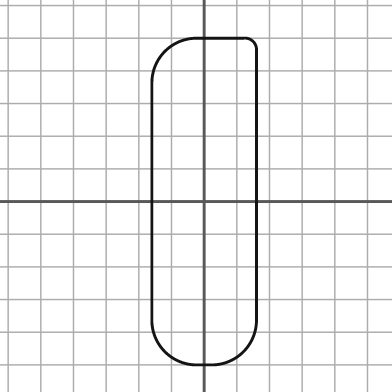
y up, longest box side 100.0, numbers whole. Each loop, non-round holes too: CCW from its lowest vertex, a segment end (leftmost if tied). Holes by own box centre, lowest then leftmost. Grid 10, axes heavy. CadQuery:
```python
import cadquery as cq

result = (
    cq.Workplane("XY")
    .moveTo(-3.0, -50.0)
    .lineTo(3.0, -50.0)
    .threePointArc((12.0, -46.0), (16.0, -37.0))
    .lineTo(16.0, 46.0)
    .threePointArc((15.0, 49.0), (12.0, 50.0))
    .lineTo(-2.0, 50.0)
    .threePointArc((-12.0, 46.0), (-16.0, 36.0))
    .lineTo(-16.0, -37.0)
    .threePointArc((-12.0, -46.0), (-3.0, -50.0))
    .close()
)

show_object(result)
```